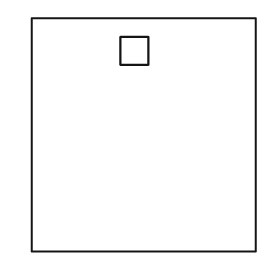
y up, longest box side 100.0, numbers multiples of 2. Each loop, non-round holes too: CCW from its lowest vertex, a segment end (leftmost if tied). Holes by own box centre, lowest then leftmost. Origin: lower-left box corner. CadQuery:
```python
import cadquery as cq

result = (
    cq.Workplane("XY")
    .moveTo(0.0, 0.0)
    .lineTo(96.0, 0.0)
    .lineTo(96.0, 100.0)
    .lineTo(0.0, 100.0)
    .close()
    .moveTo(38.0, 80.0)
    .lineTo(50.0, 80.0)
    .lineTo(50.0, 92.0)
    .lineTo(38.0, 92.0)
    .close()
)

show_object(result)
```